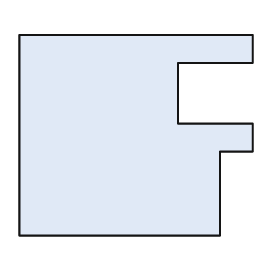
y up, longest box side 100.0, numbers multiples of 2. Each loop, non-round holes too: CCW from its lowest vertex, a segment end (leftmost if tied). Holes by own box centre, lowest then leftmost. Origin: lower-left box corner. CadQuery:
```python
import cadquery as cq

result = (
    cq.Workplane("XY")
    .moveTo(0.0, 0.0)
    .lineTo(86.0, 0.0)
    .lineTo(86.0, 36.0)
    .lineTo(100.0, 36.0)
    .lineTo(100.0, 48.0)
    .lineTo(68.0, 48.0)
    .lineTo(68.0, 74.0)
    .lineTo(100.0, 74.0)
    .lineTo(100.0, 86.0)
    .lineTo(0.0, 86.0)
    .close()
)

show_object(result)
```